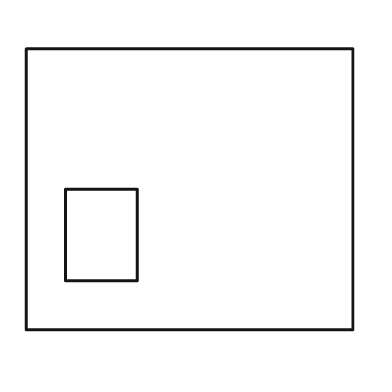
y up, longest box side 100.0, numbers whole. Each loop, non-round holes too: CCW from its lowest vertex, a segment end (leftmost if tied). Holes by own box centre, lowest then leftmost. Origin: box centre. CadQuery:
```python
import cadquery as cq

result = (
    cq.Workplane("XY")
    .moveTo(-50.0, -43.0)
    .lineTo(50.0, -43.0)
    .lineTo(50.0, 43.0)
    .lineTo(-50.0, 43.0)
    .close()
    .moveTo(-38.0, -28.0)
    .lineTo(-16.0, -28.0)
    .lineTo(-16.0, 0.0)
    .lineTo(-38.0, 0.0)
    .close()
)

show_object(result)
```